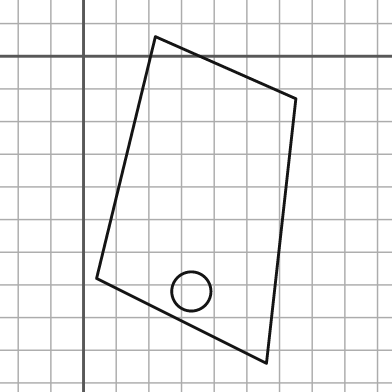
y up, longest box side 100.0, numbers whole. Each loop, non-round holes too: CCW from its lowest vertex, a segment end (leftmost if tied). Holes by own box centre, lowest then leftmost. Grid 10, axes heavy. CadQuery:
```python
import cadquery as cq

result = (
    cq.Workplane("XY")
    .moveTo(56.0, -94.0)
    .lineTo(65.0, -13.0)
    .lineTo(22.0, 6.0)
    .lineTo(4.0, -68.0)
    .close()
    .moveTo(33.0, -72.0)
    .circle(6.0)
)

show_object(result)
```